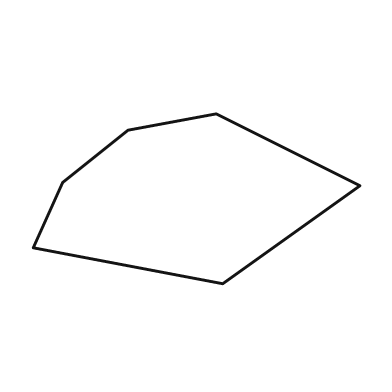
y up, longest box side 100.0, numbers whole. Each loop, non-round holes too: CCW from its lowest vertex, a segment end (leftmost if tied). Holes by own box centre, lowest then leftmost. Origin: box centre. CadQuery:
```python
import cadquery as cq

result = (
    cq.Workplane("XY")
    .moveTo(8.0, -26.0)
    .lineTo(50.0, 4.0)
    .lineTo(6.0, 26.0)
    .lineTo(-21.0, 21.0)
    .lineTo(-41.0, 5.0)
    .lineTo(-50.0, -15.0)
    .close()
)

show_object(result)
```